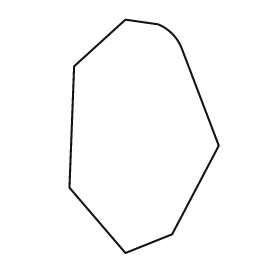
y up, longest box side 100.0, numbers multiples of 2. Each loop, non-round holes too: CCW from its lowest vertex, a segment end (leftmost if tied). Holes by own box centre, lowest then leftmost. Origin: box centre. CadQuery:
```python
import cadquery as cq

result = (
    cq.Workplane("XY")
    .moveTo(-8.0, -50.0)
    .lineTo(12.0, -42.0)
    .lineTo(32.0, -4.0)
    .lineTo(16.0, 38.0)
    .threePointArc((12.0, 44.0), (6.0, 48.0))
    .lineTo(-8.0, 50.0)
    .lineTo(-30.0, 30.0)
    .lineTo(-32.0, -22.0)
    .close()
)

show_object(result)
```